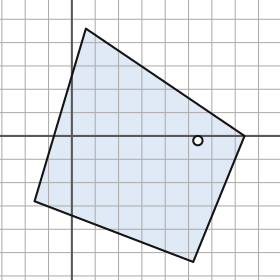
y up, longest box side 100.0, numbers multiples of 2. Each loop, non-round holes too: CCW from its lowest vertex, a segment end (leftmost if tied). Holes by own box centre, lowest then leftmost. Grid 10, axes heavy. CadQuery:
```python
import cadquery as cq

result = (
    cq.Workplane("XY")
    .moveTo(52.0, -54.0)
    .lineTo(74.0, 0.0)
    .lineTo(6.0, 46.0)
    .lineTo(-16.0, -28.0)
    .close()
    .moveTo(54.0, -2.0)
    .circle(2.0)
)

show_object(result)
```